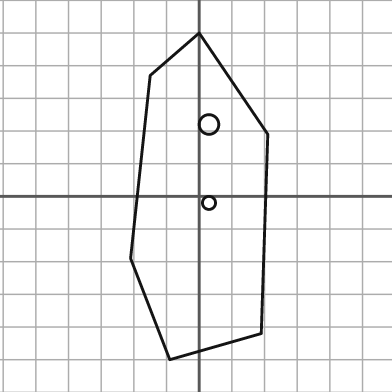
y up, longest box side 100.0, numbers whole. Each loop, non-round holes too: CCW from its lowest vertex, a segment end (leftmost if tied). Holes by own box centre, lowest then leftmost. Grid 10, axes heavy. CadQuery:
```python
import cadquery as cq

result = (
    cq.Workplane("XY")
    .moveTo(-9.0, -50.0)
    .lineTo(19.0, -42.0)
    .lineTo(21.0, 19.0)
    .lineTo(0.0, 50.0)
    .lineTo(-15.0, 37.0)
    .lineTo(-21.0, -19.0)
    .close()
    .moveTo(3.0, -2.0)
    .circle(2.0)
    .moveTo(3.0, 22.0)
    .circle(3.0)
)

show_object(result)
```